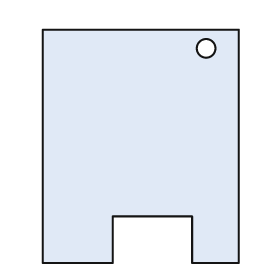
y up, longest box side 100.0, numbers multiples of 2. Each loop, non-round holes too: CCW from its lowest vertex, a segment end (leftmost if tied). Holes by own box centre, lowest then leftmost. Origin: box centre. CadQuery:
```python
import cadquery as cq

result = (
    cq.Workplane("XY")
    .moveTo(-42.0, -50.0)
    .lineTo(-12.0, -50.0)
    .lineTo(-12.0, -30.0)
    .lineTo(22.0, -30.0)
    .lineTo(22.0, -50.0)
    .lineTo(42.0, -50.0)
    .lineTo(42.0, 50.0)
    .lineTo(-42.0, 50.0)
    .close()
    .moveTo(28.0, 42.0)
    .circle(4.0)
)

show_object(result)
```